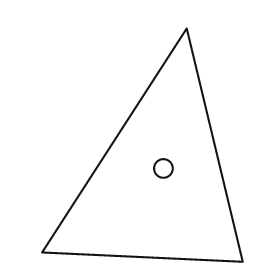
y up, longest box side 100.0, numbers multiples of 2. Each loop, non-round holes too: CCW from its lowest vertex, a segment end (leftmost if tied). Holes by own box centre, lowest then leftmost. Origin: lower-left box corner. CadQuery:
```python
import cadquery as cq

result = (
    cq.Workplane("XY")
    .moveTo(86.0, 0.0)
    .lineTo(62.0, 100.0)
    .lineTo(0.0, 4.0)
    .close()
    .moveTo(52.0, 40.0)
    .circle(4.0)
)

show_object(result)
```